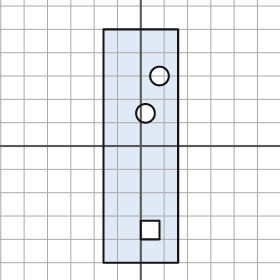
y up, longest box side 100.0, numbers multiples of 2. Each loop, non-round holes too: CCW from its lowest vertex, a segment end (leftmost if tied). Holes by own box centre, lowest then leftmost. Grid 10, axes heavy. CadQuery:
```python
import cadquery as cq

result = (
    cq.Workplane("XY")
    .moveTo(-16.0, -50.0)
    .lineTo(16.0, -50.0)
    .lineTo(16.0, 50.0)
    .lineTo(-16.0, 50.0)
    .close()
    .moveTo(0.0, -40.0)
    .lineTo(8.0, -40.0)
    .lineTo(8.0, -32.0)
    .lineTo(0.0, -32.0)
    .close()
    .moveTo(2.0, 14.0)
    .circle(4.0)
    .moveTo(8.0, 30.0)
    .circle(4.0)
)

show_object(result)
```